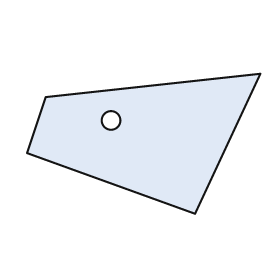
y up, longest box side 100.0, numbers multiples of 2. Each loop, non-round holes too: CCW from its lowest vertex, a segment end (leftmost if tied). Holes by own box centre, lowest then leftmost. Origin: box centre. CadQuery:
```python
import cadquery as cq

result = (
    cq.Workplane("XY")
    .moveTo(22.0, -30.0)
    .lineTo(50.0, 30.0)
    .lineTo(-42.0, 20.0)
    .lineTo(-50.0, -4.0)
    .close()
    .moveTo(-14.0, 10.0)
    .circle(4.0)
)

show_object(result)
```